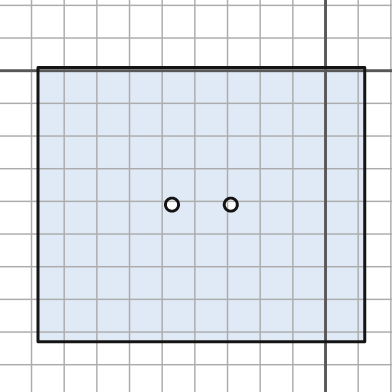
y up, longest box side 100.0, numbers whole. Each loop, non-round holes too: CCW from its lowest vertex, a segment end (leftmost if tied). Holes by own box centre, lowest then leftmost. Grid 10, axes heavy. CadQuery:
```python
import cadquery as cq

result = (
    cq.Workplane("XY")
    .moveTo(-88.0, -83.0)
    .lineTo(12.0, -83.0)
    .lineTo(12.0, 1.0)
    .lineTo(-88.0, 1.0)
    .close()
    .moveTo(-47.0, -41.0)
    .circle(2.0)
    .moveTo(-29.0, -41.0)
    .circle(2.0)
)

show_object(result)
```